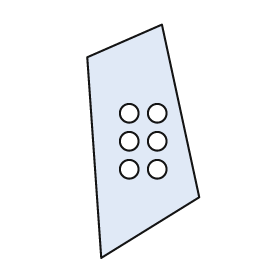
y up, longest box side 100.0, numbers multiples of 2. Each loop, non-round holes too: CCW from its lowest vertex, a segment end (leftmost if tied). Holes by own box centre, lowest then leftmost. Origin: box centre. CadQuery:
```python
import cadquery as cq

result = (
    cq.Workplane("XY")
    .moveTo(-18.0, -50.0)
    .lineTo(24.0, -24.0)
    .lineTo(8.0, 50.0)
    .lineTo(-24.0, 36.0)
    .close()
    .moveTo(-6.0, -12.0)
    .circle(4.0)
    .moveTo(6.0, -12.0)
    .circle(4.0)
    .moveTo(-6.0, 0.0)
    .circle(4.0)
    .moveTo(6.0, 0.0)
    .circle(4.0)
    .moveTo(-6.0, 12.0)
    .circle(4.0)
    .moveTo(6.0, 12.0)
    .circle(4.0)
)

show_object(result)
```